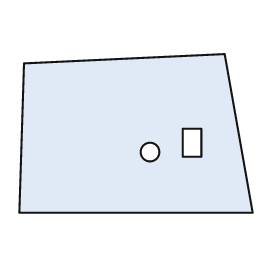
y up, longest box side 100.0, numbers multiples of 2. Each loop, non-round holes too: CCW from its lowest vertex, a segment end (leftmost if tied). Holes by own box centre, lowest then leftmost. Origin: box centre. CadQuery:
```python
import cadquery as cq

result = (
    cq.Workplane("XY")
    .moveTo(-50.0, -34.0)
    .lineTo(50.0, -34.0)
    .lineTo(38.0, 34.0)
    .lineTo(-48.0, 30.0)
    .close()
    .moveTo(6.0, -8.0)
    .circle(4.0)
    .moveTo(20.0, -10.0)
    .lineTo(28.0, -10.0)
    .lineTo(28.0, 2.0)
    .lineTo(20.0, 2.0)
    .close()
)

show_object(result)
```